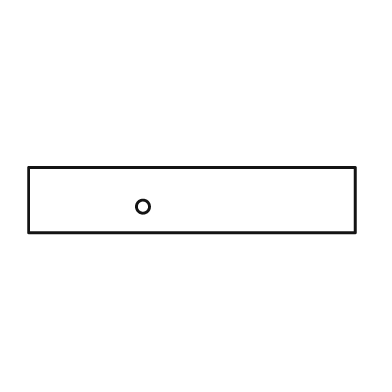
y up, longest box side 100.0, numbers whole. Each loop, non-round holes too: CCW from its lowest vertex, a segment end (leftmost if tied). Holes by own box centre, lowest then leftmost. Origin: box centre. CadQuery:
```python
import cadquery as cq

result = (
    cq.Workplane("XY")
    .moveTo(-50.0, -10.0)
    .lineTo(50.0, -10.0)
    .lineTo(50.0, 10.0)
    .lineTo(-50.0, 10.0)
    .close()
    .moveTo(-15.0, -2.0)
    .circle(2.0)
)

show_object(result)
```